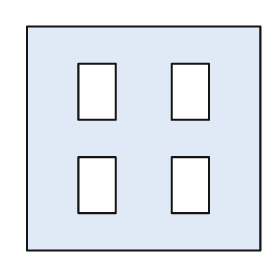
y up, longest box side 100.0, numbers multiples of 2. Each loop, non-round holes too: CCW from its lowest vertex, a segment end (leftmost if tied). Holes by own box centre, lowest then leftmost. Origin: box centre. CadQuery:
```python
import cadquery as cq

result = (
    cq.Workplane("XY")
    .moveTo(-50.0, -48.0)
    .lineTo(50.0, -48.0)
    .lineTo(50.0, 48.0)
    .lineTo(-50.0, 48.0)
    .close()
    .moveTo(-28.0, -32.0)
    .lineTo(-12.0, -32.0)
    .lineTo(-12.0, -8.0)
    .lineTo(-28.0, -8.0)
    .close()
    .moveTo(12.0, -32.0)
    .lineTo(28.0, -32.0)
    .lineTo(28.0, -8.0)
    .lineTo(12.0, -8.0)
    .close()
    .moveTo(-28.0, 8.0)
    .lineTo(-12.0, 8.0)
    .lineTo(-12.0, 32.0)
    .lineTo(-28.0, 32.0)
    .close()
    .moveTo(12.0, 8.0)
    .lineTo(28.0, 8.0)
    .lineTo(28.0, 32.0)
    .lineTo(12.0, 32.0)
    .close()
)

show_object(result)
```